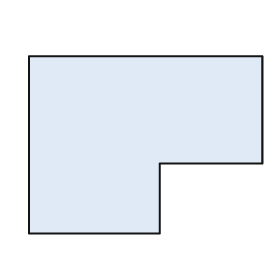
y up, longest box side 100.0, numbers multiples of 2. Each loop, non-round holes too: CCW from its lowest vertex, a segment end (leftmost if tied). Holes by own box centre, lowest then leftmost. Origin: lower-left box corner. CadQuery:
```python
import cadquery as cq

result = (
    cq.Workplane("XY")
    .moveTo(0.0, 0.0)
    .lineTo(56.0, 0.0)
    .lineTo(56.0, 30.0)
    .lineTo(100.0, 30.0)
    .lineTo(100.0, 76.0)
    .lineTo(0.0, 76.0)
    .close()
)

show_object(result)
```